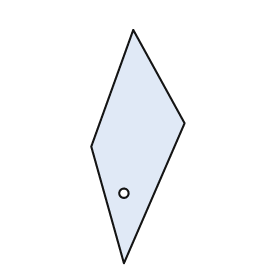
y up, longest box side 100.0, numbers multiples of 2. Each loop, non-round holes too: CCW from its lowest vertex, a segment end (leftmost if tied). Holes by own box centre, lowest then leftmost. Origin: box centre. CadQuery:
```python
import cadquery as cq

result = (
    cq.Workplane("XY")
    .moveTo(-6.0, -50.0)
    .lineTo(20.0, 10.0)
    .lineTo(-2.0, 50.0)
    .lineTo(-20.0, 0.0)
    .close()
    .moveTo(-6.0, -20.0)
    .circle(2.0)
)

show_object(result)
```